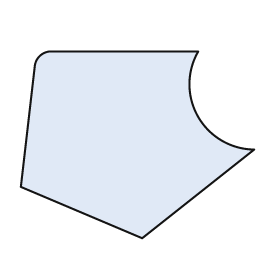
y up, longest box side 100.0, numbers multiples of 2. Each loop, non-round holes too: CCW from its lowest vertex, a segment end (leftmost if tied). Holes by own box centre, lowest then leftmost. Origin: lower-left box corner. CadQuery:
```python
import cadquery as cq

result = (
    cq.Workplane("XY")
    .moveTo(52.0, 0.0)
    .lineTo(100.0, 38.0)
    .threePointArc((76.0, 52.0), (76.0, 80.0))
    .lineTo(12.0, 80.0)
    .threePointArc((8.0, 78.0), (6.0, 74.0))
    .lineTo(0.0, 22.0)
    .close()
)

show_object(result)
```